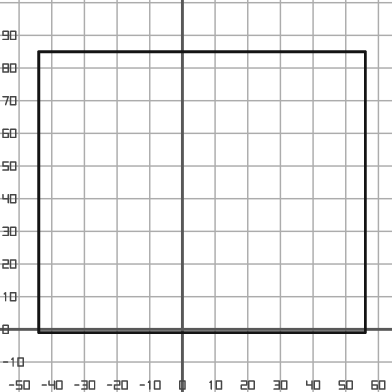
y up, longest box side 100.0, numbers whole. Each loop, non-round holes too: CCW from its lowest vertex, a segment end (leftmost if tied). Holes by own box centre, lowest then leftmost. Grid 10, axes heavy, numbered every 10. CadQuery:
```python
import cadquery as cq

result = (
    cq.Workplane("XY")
    .moveTo(-44.0, -1.0)
    .lineTo(56.0, -1.0)
    .lineTo(56.0, 85.0)
    .lineTo(-44.0, 85.0)
    .close()
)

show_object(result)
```